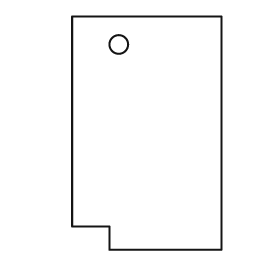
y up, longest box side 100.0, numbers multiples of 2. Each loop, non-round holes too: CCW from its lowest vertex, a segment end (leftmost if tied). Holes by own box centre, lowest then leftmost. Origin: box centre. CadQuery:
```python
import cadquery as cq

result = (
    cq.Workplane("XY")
    .moveTo(-16.0, -50.0)
    .lineTo(32.0, -50.0)
    .lineTo(32.0, 50.0)
    .lineTo(-32.0, 50.0)
    .lineTo(-32.0, -40.0)
    .lineTo(-16.0, -40.0)
    .close()
    .moveTo(-12.0, 38.0)
    .circle(4.0)
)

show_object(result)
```